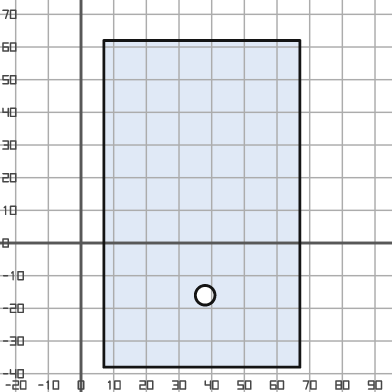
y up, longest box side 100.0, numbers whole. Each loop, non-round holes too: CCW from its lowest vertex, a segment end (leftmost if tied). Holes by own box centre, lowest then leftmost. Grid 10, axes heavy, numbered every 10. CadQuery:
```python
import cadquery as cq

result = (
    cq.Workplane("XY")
    .moveTo(7.0, -38.0)
    .lineTo(67.0, -38.0)
    .lineTo(67.0, 62.0)
    .lineTo(7.0, 62.0)
    .close()
    .moveTo(38.0, -16.0)
    .circle(3.0)
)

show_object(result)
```